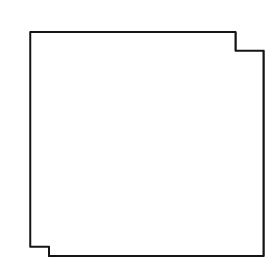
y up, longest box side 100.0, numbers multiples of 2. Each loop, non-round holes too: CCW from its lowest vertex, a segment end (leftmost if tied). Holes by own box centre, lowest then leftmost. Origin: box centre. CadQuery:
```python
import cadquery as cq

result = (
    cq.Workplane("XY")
    .moveTo(-42.0, -48.0)
    .lineTo(50.0, -48.0)
    .lineTo(50.0, 40.0)
    .lineTo(38.0, 40.0)
    .lineTo(38.0, 48.0)
    .lineTo(-50.0, 48.0)
    .lineTo(-50.0, -44.0)
    .lineTo(-42.0, -44.0)
    .close()
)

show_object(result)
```